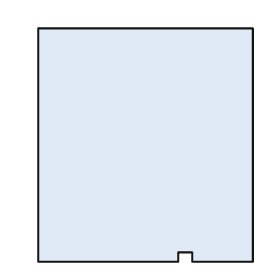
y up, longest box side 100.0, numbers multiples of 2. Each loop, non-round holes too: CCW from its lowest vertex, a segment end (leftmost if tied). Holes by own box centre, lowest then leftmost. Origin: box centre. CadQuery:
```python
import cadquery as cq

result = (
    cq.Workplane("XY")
    .moveTo(-46.0, -50.0)
    .lineTo(14.0, -50.0)
    .lineTo(14.0, -46.0)
    .lineTo(20.0, -46.0)
    .lineTo(20.0, -50.0)
    .lineTo(46.0, -50.0)
    .lineTo(46.0, 50.0)
    .lineTo(-46.0, 50.0)
    .close()
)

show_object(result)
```